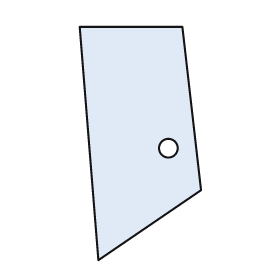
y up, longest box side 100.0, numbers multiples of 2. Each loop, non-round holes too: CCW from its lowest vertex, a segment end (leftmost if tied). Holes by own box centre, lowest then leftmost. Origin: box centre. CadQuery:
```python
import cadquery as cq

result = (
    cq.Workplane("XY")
    .moveTo(-18.0, -50.0)
    .lineTo(26.0, -20.0)
    .lineTo(18.0, 50.0)
    .lineTo(-26.0, 50.0)
    .close()
    .moveTo(12.0, -2.0)
    .circle(4.0)
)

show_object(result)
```